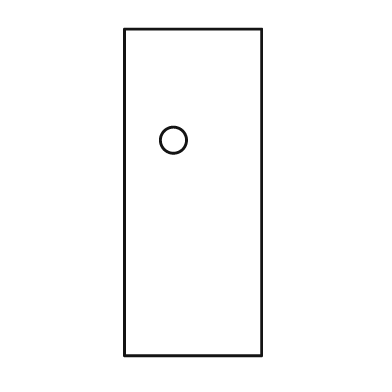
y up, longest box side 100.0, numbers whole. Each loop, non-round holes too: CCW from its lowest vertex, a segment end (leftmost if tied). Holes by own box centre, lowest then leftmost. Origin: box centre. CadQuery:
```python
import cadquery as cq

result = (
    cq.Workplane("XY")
    .moveTo(-21.0, -50.0)
    .lineTo(21.0, -50.0)
    .lineTo(21.0, 50.0)
    .lineTo(-21.0, 50.0)
    .close()
    .moveTo(-6.0, 16.0)
    .circle(4.0)
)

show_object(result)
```